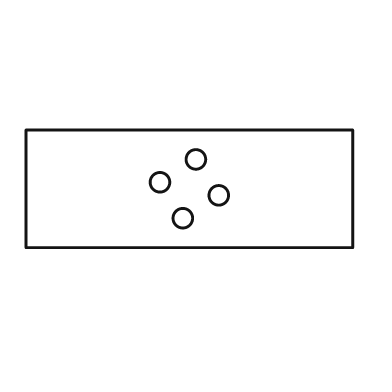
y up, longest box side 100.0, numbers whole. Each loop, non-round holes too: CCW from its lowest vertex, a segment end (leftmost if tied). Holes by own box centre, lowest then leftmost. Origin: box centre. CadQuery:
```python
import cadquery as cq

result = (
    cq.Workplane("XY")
    .moveTo(-50.0, -18.0)
    .lineTo(50.0, -18.0)
    .lineTo(50.0, 18.0)
    .lineTo(-50.0, 18.0)
    .close()
    .moveTo(-2.0, -9.0)
    .circle(3.0)
    .moveTo(9.0, -2.0)
    .circle(3.0)
    .moveTo(-9.0, 2.0)
    .circle(3.0)
    .moveTo(2.0, 9.0)
    .circle(3.0)
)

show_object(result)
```